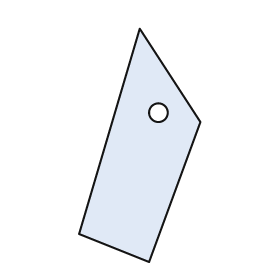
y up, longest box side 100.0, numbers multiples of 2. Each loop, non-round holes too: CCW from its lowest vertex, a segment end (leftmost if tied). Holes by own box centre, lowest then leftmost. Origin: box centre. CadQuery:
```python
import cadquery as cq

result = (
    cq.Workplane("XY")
    .moveTo(4.0, -50.0)
    .lineTo(26.0, 10.0)
    .lineTo(0.0, 50.0)
    .lineTo(-26.0, -38.0)
    .close()
    .moveTo(8.0, 14.0)
    .circle(4.0)
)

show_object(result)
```